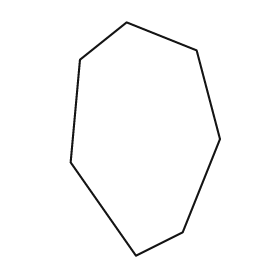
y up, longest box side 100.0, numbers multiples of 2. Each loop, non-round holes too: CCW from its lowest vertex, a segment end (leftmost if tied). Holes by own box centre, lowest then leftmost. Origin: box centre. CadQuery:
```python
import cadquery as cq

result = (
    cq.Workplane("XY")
    .moveTo(-4.0, -50.0)
    .lineTo(16.0, -40.0)
    .lineTo(32.0, 0.0)
    .lineTo(22.0, 38.0)
    .lineTo(-8.0, 50.0)
    .lineTo(-28.0, 34.0)
    .lineTo(-32.0, -10.0)
    .close()
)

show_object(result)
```